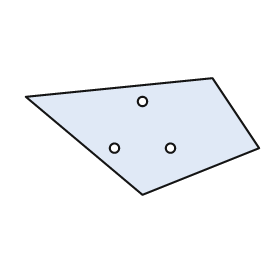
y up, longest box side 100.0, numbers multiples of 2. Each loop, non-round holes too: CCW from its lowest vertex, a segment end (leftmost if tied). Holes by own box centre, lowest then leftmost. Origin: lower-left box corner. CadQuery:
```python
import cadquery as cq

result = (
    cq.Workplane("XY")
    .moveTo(50.0, 0.0)
    .lineTo(100.0, 20.0)
    .lineTo(80.0, 50.0)
    .lineTo(0.0, 42.0)
    .close()
    .moveTo(38.0, 20.0)
    .circle(2.0)
    .moveTo(62.0, 20.0)
    .circle(2.0)
    .moveTo(50.0, 40.0)
    .circle(2.0)
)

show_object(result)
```